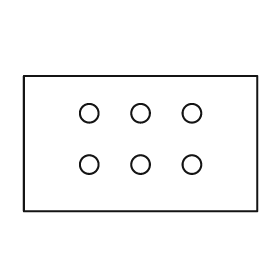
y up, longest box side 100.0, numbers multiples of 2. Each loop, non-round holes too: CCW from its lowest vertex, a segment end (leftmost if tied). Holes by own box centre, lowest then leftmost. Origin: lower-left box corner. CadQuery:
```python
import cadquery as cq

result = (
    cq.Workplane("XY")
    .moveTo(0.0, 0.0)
    .lineTo(100.0, 0.0)
    .lineTo(100.0, 58.0)
    .lineTo(0.0, 58.0)
    .close()
    .moveTo(28.0, 20.0)
    .circle(4.0)
    .moveTo(50.0, 20.0)
    .circle(4.0)
    .moveTo(72.0, 20.0)
    .circle(4.0)
    .moveTo(28.0, 42.0)
    .circle(4.0)
    .moveTo(50.0, 42.0)
    .circle(4.0)
    .moveTo(72.0, 42.0)
    .circle(4.0)
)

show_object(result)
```